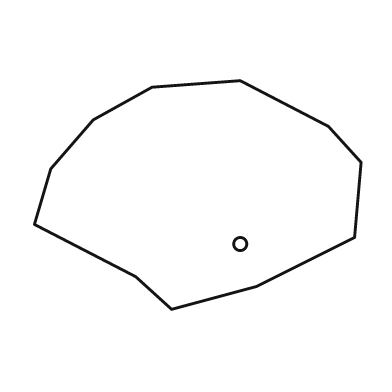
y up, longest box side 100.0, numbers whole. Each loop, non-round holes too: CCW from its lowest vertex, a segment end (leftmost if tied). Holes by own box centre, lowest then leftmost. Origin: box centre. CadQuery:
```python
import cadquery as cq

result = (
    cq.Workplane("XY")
    .moveTo(-8.0, -35.0)
    .lineTo(18.0, -28.0)
    .lineTo(48.0, -13.0)
    .lineTo(50.0, 10.0)
    .lineTo(40.0, 21.0)
    .lineTo(13.0, 35.0)
    .lineTo(-14.0, 33.0)
    .lineTo(-32.0, 23.0)
    .lineTo(-45.0, 8.0)
    .lineTo(-50.0, -9.0)
    .lineTo(-19.0, -25.0)
    .close()
    .moveTo(13.0, -15.0)
    .circle(2.0)
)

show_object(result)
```